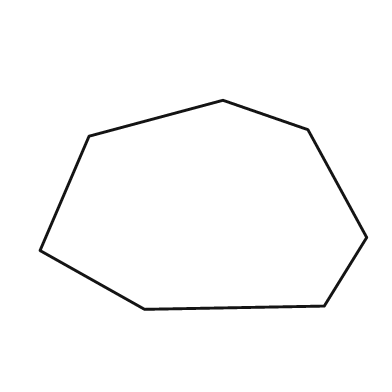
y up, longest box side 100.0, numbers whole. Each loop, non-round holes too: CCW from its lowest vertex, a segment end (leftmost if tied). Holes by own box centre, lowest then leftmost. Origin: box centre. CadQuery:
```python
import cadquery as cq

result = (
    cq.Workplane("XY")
    .moveTo(-18.0, -32.0)
    .lineTo(37.0, -31.0)
    .lineTo(50.0, -10.0)
    .lineTo(32.0, 23.0)
    .lineTo(6.0, 32.0)
    .lineTo(-35.0, 21.0)
    .lineTo(-50.0, -14.0)
    .close()
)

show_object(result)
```